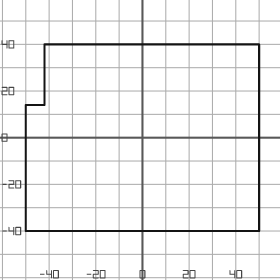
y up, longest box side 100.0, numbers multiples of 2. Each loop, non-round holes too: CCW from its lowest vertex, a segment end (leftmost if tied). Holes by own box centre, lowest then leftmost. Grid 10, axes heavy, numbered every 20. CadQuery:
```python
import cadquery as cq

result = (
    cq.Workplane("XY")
    .moveTo(-50.0, -40.0)
    .lineTo(50.0, -40.0)
    .lineTo(50.0, 40.0)
    .lineTo(-42.0, 40.0)
    .lineTo(-42.0, 14.0)
    .lineTo(-50.0, 14.0)
    .close()
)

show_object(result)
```